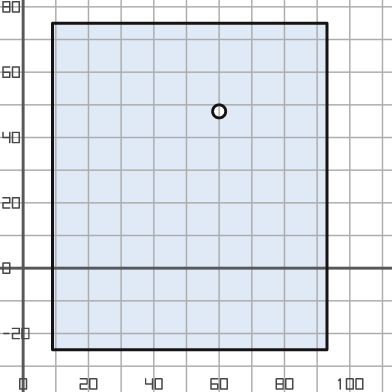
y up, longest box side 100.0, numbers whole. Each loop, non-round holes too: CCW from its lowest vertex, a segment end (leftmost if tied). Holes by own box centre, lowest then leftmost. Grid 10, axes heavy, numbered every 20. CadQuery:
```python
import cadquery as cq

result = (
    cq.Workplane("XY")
    .moveTo(9.0, -25.0)
    .lineTo(93.0, -25.0)
    .lineTo(93.0, 75.0)
    .lineTo(9.0, 75.0)
    .close()
    .moveTo(60.0, 48.0)
    .circle(2.0)
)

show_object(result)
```